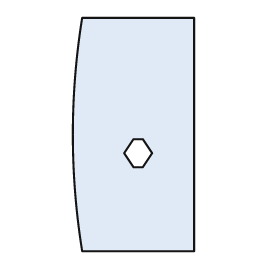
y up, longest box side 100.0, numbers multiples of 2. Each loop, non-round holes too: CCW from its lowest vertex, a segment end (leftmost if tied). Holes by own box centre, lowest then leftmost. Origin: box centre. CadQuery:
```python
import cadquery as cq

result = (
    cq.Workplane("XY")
    .moveTo(-22.0, -50.0)
    .lineTo(26.0, -50.0)
    .lineTo(26.0, 50.0)
    .lineTo(-22.0, 50.0)
    .threePointArc((-26.0, 0.0), (-22.0, -50.0))
    .close()
    .moveTo(0.0, -14.0)
    .lineTo(4.0, -14.0)
    .lineTo(8.0, -8.0)
    .lineTo(4.0, -2.0)
    .lineTo(0.0, -2.0)
    .lineTo(-4.0, -8.0)
    .close()
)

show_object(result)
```